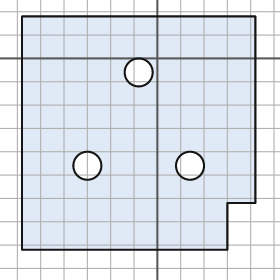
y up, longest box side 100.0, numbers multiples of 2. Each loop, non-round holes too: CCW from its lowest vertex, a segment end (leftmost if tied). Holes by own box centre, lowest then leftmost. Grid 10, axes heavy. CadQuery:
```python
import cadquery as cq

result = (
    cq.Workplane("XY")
    .moveTo(-58.0, -82.0)
    .lineTo(30.0, -82.0)
    .lineTo(30.0, -62.0)
    .lineTo(42.0, -62.0)
    .lineTo(42.0, 18.0)
    .lineTo(-58.0, 18.0)
    .close()
    .moveTo(-30.0, -46.0)
    .circle(6.0)
    .moveTo(14.0, -46.0)
    .circle(6.0)
    .moveTo(-8.0, -6.0)
    .circle(6.0)
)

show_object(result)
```